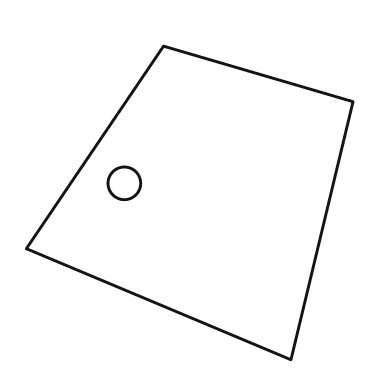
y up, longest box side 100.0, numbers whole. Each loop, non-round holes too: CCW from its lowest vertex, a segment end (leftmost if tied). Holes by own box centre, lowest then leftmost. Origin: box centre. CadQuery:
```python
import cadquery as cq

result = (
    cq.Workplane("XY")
    .moveTo(31.0, -48.0)
    .lineTo(50.0, 31.0)
    .lineTo(-8.0, 48.0)
    .lineTo(-50.0, -14.0)
    .close()
    .moveTo(-20.0, 6.0)
    .circle(5.0)
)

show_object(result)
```